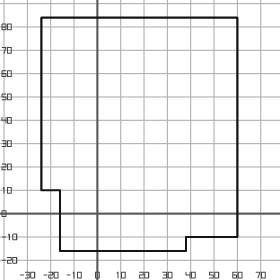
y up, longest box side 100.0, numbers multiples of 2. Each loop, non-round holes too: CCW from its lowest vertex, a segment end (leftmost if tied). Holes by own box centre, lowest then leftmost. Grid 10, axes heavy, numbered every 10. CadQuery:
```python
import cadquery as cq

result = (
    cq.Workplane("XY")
    .moveTo(-16.0, -16.0)
    .lineTo(38.0, -16.0)
    .lineTo(38.0, -10.0)
    .lineTo(60.0, -10.0)
    .lineTo(60.0, 84.0)
    .lineTo(-24.0, 84.0)
    .lineTo(-24.0, 10.0)
    .lineTo(-16.0, 10.0)
    .close()
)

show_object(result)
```